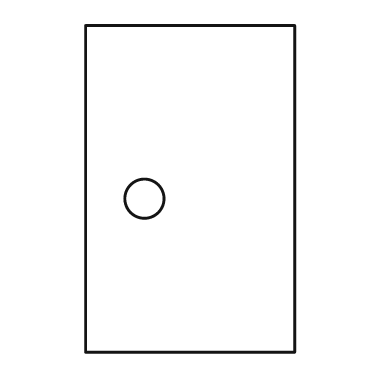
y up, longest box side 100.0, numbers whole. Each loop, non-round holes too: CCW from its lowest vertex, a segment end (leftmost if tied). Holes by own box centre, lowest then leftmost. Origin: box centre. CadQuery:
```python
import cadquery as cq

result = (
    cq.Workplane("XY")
    .moveTo(-32.0, -50.0)
    .lineTo(32.0, -50.0)
    .lineTo(32.0, 50.0)
    .lineTo(-32.0, 50.0)
    .close()
    .moveTo(-14.0, -3.0)
    .circle(6.0)
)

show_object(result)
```